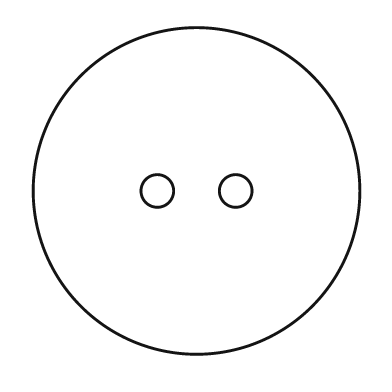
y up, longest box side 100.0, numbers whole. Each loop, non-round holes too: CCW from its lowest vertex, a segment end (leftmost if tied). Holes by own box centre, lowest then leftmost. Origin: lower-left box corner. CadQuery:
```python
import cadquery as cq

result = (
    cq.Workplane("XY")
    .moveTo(50.0, 50.0)
    .circle(50.0)
    .moveTo(38.0, 50.0)
    .circle(5.0)
    .moveTo(62.0, 50.0)
    .circle(5.0)
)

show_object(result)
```